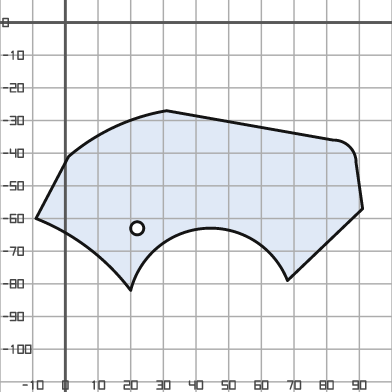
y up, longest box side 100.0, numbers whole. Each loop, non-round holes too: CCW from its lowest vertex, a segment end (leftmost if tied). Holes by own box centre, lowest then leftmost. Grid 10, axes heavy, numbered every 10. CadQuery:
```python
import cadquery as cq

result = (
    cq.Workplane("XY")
    .moveTo(20.0, -82.0)
    .threePointArc((43.0, -63.0), (68.0, -79.0))
    .lineTo(91.0, -57.0)
    .lineTo(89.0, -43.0)
    .threePointArc((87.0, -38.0), (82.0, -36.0))
    .lineTo(31.0, -27.0)
    .threePointArc((15.0, -32.0), (1.0, -41.0))
    .lineTo(-9.0, -60.0)
    .threePointArc((7.0, -69.0), (20.0, -82.0))
    .close()
    .moveTo(22.0, -63.0)
    .circle(2.0)
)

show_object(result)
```